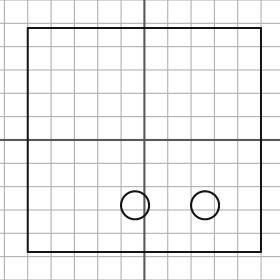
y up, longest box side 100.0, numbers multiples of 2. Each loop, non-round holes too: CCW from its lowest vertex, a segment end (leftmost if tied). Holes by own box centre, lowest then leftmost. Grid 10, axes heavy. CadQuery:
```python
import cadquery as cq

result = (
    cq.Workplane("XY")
    .moveTo(-50.0, -48.0)
    .lineTo(50.0, -48.0)
    .lineTo(50.0, 48.0)
    .lineTo(-50.0, 48.0)
    .close()
    .moveTo(-4.0, -28.0)
    .circle(6.0)
    .moveTo(26.0, -28.0)
    .circle(6.0)
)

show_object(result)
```